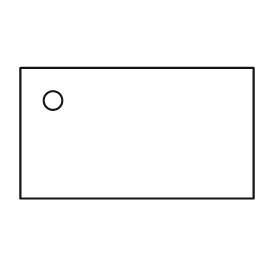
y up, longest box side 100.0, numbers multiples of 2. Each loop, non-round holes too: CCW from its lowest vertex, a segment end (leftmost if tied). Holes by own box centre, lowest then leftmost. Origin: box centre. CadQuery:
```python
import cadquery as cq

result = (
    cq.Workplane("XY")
    .moveTo(-50.0, -28.0)
    .lineTo(50.0, -28.0)
    .lineTo(50.0, 28.0)
    .lineTo(-50.0, 28.0)
    .close()
    .moveTo(-36.0, 14.0)
    .circle(4.0)
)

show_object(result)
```